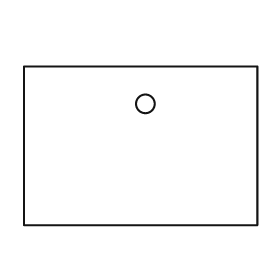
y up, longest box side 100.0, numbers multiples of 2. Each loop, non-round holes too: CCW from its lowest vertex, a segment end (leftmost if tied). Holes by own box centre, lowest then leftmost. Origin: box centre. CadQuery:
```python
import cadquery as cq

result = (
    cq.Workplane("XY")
    .moveTo(-50.0, -34.0)
    .lineTo(50.0, -34.0)
    .lineTo(50.0, 34.0)
    .lineTo(-50.0, 34.0)
    .close()
    .moveTo(2.0, 18.0)
    .circle(4.0)
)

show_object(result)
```